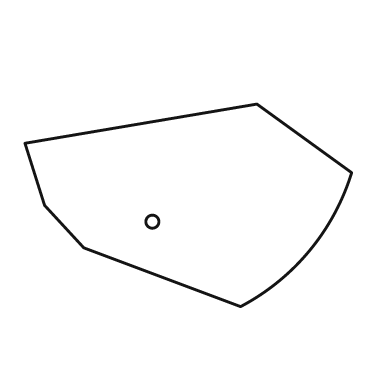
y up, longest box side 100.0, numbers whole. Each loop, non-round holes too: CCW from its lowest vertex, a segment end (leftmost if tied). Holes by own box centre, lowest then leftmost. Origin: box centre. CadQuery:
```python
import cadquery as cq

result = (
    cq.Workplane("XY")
    .moveTo(16.0, -31.0)
    .threePointArc((37.0, -14.0), (50.0, 10.0))
    .lineTo(21.0, 31.0)
    .lineTo(-50.0, 19.0)
    .lineTo(-44.0, 0.0)
    .lineTo(-32.0, -13.0)
    .close()
    .moveTo(-11.0, -5.0)
    .circle(2.0)
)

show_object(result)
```